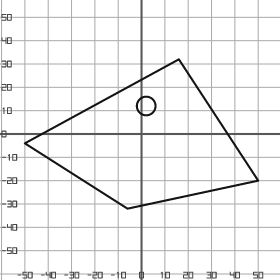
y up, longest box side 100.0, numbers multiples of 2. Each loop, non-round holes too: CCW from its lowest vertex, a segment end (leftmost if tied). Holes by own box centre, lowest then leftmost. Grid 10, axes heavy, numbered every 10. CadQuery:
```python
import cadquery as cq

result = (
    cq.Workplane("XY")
    .moveTo(-6.0, -32.0)
    .lineTo(50.0, -20.0)
    .lineTo(16.0, 32.0)
    .lineTo(-50.0, -4.0)
    .close()
    .moveTo(2.0, 12.0)
    .circle(4.0)
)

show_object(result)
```